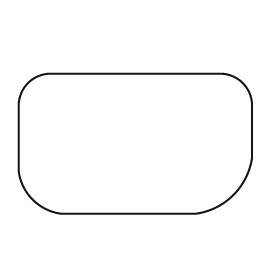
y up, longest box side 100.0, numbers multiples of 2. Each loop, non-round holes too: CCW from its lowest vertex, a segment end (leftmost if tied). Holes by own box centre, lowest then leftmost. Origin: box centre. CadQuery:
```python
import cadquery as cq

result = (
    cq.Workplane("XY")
    .moveTo(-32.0, -30.0)
    .lineTo(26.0, -30.0)
    .threePointArc((42.0, -22.0), (50.0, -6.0))
    .lineTo(50.0, 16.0)
    .threePointArc((46.0, 26.0), (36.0, 30.0))
    .lineTo(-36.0, 30.0)
    .threePointArc((-46.0, 26.0), (-50.0, 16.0))
    .lineTo(-50.0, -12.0)
    .threePointArc((-44.0, -24.0), (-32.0, -30.0))
    .close()
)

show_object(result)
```